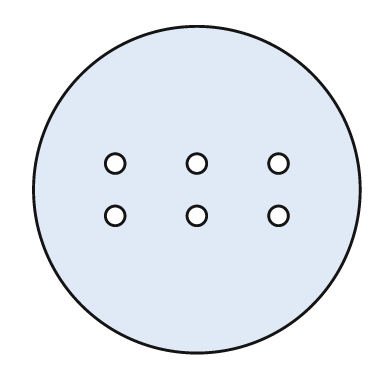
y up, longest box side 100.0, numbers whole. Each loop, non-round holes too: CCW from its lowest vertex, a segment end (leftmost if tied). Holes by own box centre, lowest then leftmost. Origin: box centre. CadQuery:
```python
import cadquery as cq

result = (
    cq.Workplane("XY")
    .moveTo(0.0, 0.0)
    .circle(50.0)
    .moveTo(-25.0, -8.0)
    .circle(3.0)
    .moveTo(0.0, -8.0)
    .circle(3.0)
    .moveTo(25.0, -8.0)
    .circle(3.0)
    .moveTo(-25.0, 8.0)
    .circle(3.0)
    .moveTo(0.0, 8.0)
    .circle(3.0)
    .moveTo(25.0, 8.0)
    .circle(3.0)
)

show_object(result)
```